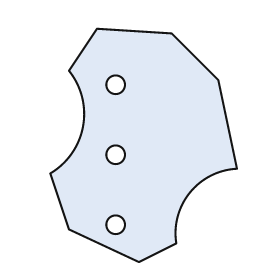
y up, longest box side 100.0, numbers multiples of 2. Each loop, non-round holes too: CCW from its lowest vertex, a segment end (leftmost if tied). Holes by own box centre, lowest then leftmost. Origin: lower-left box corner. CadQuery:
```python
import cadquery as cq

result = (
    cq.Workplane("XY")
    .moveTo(38.0, 0.0)
    .lineTo(54.0, 8.0)
    .threePointArc((60.0, 30.0), (80.0, 40.0))
    .lineTo(72.0, 78.0)
    .lineTo(52.0, 98.0)
    .lineTo(20.0, 100.0)
    .lineTo(8.0, 82.0)
    .threePointArc((14.0, 58.0), (0.0, 38.0))
    .lineTo(8.0, 14.0)
    .close()
    .moveTo(28.0, 16.0)
    .circle(4.0)
    .moveTo(28.0, 46.0)
    .circle(4.0)
    .moveTo(28.0, 76.0)
    .circle(4.0)
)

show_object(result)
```